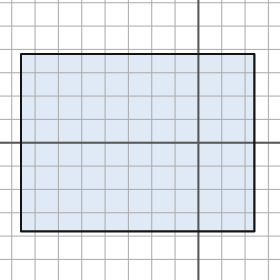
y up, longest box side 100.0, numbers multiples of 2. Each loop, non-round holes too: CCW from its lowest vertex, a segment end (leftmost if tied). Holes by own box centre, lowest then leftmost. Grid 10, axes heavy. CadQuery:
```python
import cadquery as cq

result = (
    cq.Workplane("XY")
    .moveTo(-76.0, -38.0)
    .lineTo(24.0, -38.0)
    .lineTo(24.0, 38.0)
    .lineTo(-76.0, 38.0)
    .close()
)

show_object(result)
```